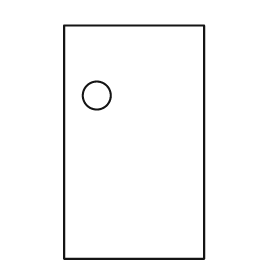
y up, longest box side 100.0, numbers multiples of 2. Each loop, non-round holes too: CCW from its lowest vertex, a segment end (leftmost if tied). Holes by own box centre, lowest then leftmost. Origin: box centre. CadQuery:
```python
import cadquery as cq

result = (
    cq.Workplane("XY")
    .moveTo(-30.0, -50.0)
    .lineTo(30.0, -50.0)
    .lineTo(30.0, 50.0)
    .lineTo(-30.0, 50.0)
    .close()
    .moveTo(-16.0, 20.0)
    .circle(6.0)
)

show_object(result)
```